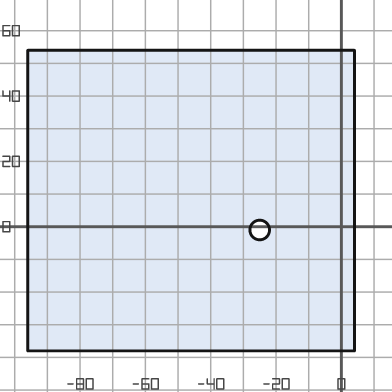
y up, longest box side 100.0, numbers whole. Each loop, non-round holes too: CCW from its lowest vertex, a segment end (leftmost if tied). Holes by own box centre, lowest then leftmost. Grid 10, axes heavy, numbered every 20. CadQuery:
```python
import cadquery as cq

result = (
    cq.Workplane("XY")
    .moveTo(-96.0, -38.0)
    .lineTo(4.0, -38.0)
    .lineTo(4.0, 54.0)
    .lineTo(-96.0, 54.0)
    .close()
    .moveTo(-25.0, -1.0)
    .circle(3.0)
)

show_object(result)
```